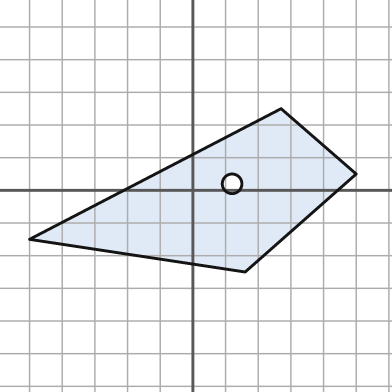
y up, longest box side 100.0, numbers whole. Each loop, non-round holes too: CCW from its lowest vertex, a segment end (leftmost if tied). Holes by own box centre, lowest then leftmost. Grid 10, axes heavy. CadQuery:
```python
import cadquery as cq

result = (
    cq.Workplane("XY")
    .moveTo(16.0, -25.0)
    .lineTo(50.0, 5.0)
    .lineTo(27.0, 25.0)
    .lineTo(-50.0, -15.0)
    .close()
    .moveTo(12.0, 2.0)
    .circle(3.0)
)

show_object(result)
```